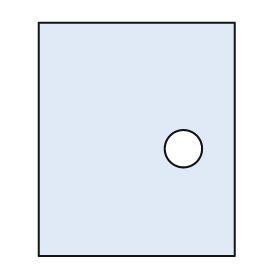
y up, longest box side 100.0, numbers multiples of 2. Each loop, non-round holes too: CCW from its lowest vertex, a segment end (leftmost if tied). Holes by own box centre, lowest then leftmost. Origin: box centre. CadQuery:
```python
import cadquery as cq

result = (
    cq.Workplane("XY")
    .moveTo(-42.0, -50.0)
    .lineTo(42.0, -50.0)
    .lineTo(42.0, 50.0)
    .lineTo(-42.0, 50.0)
    .close()
    .moveTo(20.0, -4.0)
    .circle(8.0)
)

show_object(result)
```